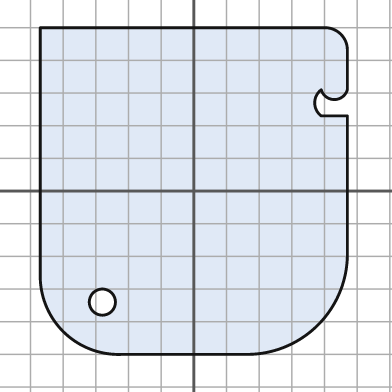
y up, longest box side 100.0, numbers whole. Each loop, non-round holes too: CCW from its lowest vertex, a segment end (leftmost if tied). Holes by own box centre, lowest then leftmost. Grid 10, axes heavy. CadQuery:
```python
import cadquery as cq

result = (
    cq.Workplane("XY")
    .moveTo(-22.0, -50.0)
    .lineTo(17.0, -50.0)
    .threePointArc((38.0, -41.0), (47.0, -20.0))
    .lineTo(47.0, 23.0)
    .lineTo(39.0, 23.0)
    .threePointArc((37.0, 27.0), (39.0, 31.0))
    .threePointArc((43.0, 28.0), (47.0, 31.0))
    .lineTo(47.0, 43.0)
    .threePointArc((45.0, 48.0), (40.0, 50.0))
    .lineTo(-47.0, 50.0)
    .lineTo(-47.0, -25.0)
    .threePointArc((-40.0, -43.0), (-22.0, -50.0))
    .close()
    .moveTo(-28.0, -34.0)
    .circle(4.0)
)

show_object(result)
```